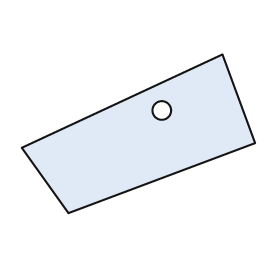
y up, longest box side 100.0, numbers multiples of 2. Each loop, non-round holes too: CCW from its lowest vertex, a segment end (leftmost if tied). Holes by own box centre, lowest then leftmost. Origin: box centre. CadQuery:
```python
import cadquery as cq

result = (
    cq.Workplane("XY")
    .moveTo(-30.0, -34.0)
    .lineTo(50.0, -4.0)
    .lineTo(36.0, 34.0)
    .lineTo(-50.0, -6.0)
    .close()
    .moveTo(10.0, 10.0)
    .circle(4.0)
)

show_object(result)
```